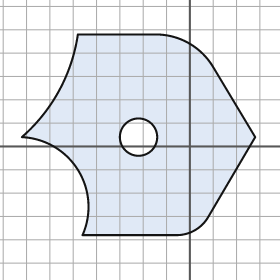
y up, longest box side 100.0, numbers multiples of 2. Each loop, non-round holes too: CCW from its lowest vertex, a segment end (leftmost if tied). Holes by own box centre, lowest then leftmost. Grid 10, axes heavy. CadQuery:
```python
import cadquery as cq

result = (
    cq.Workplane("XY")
    .moveTo(-46.0, -38.0)
    .lineTo(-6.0, -38.0)
    .threePointArc((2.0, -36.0), (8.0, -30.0))
    .lineTo(28.0, 4.0)
    .lineTo(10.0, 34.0)
    .threePointArc((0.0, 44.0), (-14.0, 48.0))
    .lineTo(-48.0, 48.0)
    .threePointArc((-56.0, 24.0), (-72.0, 4.0))
    .threePointArc((-48.0, -10.0), (-46.0, -38.0))
    .close()
    .moveTo(-22.0, 4.0)
    .circle(8.0)
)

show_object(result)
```